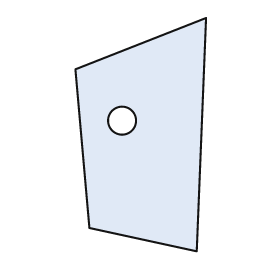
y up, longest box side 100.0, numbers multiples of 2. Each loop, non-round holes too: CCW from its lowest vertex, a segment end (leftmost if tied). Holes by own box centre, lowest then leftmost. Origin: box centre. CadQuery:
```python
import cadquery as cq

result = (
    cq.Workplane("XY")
    .moveTo(24.0, -50.0)
    .lineTo(28.0, 50.0)
    .lineTo(-28.0, 28.0)
    .lineTo(-22.0, -40.0)
    .close()
    .moveTo(-8.0, 6.0)
    .circle(6.0)
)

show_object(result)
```